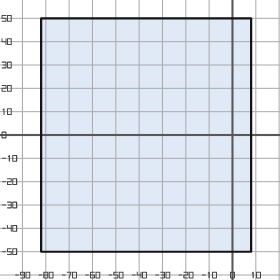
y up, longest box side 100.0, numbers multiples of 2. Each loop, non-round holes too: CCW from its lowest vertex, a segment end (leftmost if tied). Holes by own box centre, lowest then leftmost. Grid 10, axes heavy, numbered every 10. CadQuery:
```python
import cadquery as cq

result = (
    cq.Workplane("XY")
    .moveTo(-82.0, -50.0)
    .lineTo(8.0, -50.0)
    .lineTo(8.0, 50.0)
    .lineTo(-82.0, 50.0)
    .close()
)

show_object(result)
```